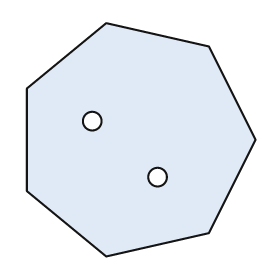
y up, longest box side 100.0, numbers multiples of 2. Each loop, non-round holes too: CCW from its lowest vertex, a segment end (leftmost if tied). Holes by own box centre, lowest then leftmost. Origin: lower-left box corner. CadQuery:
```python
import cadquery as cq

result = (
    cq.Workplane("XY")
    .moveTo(34.0, 0.0)
    .lineTo(78.0, 10.0)
    .lineTo(98.0, 50.0)
    .lineTo(78.0, 90.0)
    .lineTo(34.0, 100.0)
    .lineTo(0.0, 72.0)
    .lineTo(0.0, 28.0)
    .close()
    .moveTo(56.0, 34.0)
    .circle(4.0)
    .moveTo(28.0, 58.0)
    .circle(4.0)
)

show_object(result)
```